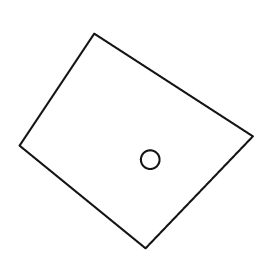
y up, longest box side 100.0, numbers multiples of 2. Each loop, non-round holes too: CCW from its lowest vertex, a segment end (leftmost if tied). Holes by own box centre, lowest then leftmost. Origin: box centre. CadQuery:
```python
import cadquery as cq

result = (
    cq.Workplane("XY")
    .moveTo(4.0, -46.0)
    .lineTo(50.0, 2.0)
    .lineTo(-18.0, 46.0)
    .lineTo(-50.0, -2.0)
    .close()
    .moveTo(6.0, -8.0)
    .circle(4.0)
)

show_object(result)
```